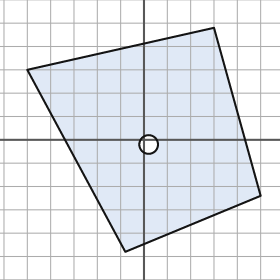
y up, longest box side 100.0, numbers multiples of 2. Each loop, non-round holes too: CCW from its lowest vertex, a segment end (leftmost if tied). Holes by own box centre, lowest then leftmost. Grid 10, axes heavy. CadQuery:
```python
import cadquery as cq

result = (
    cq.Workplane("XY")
    .moveTo(-8.0, -48.0)
    .lineTo(50.0, -24.0)
    .lineTo(30.0, 48.0)
    .lineTo(-50.0, 30.0)
    .close()
    .moveTo(2.0, -2.0)
    .circle(4.0)
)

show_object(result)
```